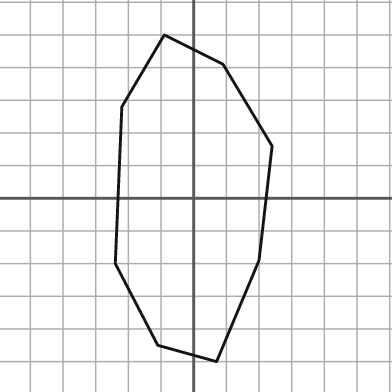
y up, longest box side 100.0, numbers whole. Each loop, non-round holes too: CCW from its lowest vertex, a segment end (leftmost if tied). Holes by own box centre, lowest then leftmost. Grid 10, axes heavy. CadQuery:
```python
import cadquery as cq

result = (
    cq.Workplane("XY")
    .moveTo(7.0, -50.0)
    .lineTo(20.0, -19.0)
    .lineTo(24.0, 16.0)
    .lineTo(9.0, 41.0)
    .lineTo(-9.0, 50.0)
    .lineTo(-22.0, 28.0)
    .lineTo(-24.0, -20.0)
    .lineTo(-11.0, -45.0)
    .close()
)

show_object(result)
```